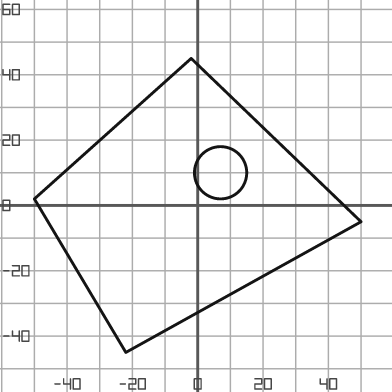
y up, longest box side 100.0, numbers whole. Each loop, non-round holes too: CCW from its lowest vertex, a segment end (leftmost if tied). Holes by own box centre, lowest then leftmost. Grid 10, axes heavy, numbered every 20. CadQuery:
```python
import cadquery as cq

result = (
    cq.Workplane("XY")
    .moveTo(-22.0, -45.0)
    .lineTo(50.0, -5.0)
    .lineTo(-2.0, 45.0)
    .lineTo(-50.0, 2.0)
    .close()
    .moveTo(7.0, 10.0)
    .circle(8.0)
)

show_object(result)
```